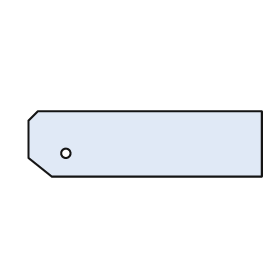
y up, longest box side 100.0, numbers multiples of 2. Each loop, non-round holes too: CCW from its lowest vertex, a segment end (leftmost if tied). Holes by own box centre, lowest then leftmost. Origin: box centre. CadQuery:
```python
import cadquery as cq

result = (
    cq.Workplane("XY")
    .moveTo(-40.0, -14.0)
    .lineTo(50.0, -14.0)
    .lineTo(50.0, 14.0)
    .lineTo(-46.0, 14.0)
    .lineTo(-50.0, 10.0)
    .lineTo(-50.0, -6.0)
    .close()
    .moveTo(-34.0, -4.0)
    .circle(2.0)
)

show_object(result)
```